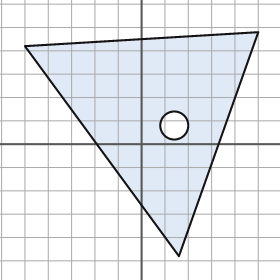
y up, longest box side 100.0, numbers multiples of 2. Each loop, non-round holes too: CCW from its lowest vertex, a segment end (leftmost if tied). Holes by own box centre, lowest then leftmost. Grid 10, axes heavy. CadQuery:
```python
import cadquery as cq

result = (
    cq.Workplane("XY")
    .moveTo(16.0, -48.0)
    .lineTo(50.0, 48.0)
    .lineTo(-50.0, 42.0)
    .close()
    .moveTo(14.0, 8.0)
    .circle(6.0)
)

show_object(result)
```